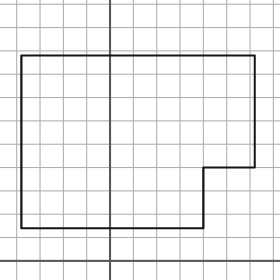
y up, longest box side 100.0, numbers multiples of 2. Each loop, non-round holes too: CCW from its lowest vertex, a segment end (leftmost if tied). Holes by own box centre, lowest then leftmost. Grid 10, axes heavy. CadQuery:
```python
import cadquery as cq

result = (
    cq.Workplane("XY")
    .moveTo(-38.0, 14.0)
    .lineTo(40.0, 14.0)
    .lineTo(40.0, 40.0)
    .lineTo(62.0, 40.0)
    .lineTo(62.0, 88.0)
    .lineTo(-38.0, 88.0)
    .close()
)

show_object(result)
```